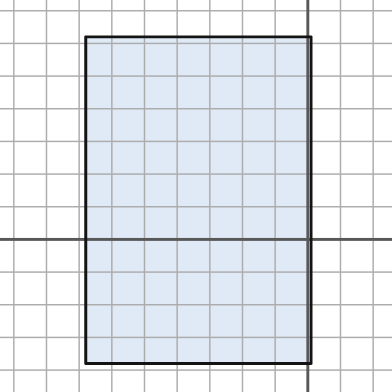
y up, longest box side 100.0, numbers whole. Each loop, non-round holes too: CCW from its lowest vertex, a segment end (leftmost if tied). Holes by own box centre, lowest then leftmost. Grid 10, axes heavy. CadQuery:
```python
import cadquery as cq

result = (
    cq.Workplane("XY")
    .moveTo(-68.0, -38.0)
    .lineTo(1.0, -38.0)
    .lineTo(1.0, 62.0)
    .lineTo(-68.0, 62.0)
    .close()
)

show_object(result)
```